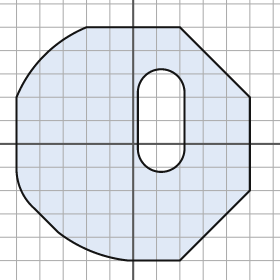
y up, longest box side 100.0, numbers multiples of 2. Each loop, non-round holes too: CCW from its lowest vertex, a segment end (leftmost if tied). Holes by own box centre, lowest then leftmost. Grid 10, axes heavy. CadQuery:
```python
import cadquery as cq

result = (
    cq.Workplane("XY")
    .moveTo(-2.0, -50.0)
    .lineTo(20.0, -50.0)
    .lineTo(50.0, -20.0)
    .lineTo(50.0, 20.0)
    .lineTo(20.0, 50.0)
    .lineTo(-20.0, 50.0)
    .threePointArc((-38.0, 38.0), (-50.0, 20.0))
    .lineTo(-50.0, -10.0)
    .threePointArc((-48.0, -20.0), (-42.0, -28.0))
    .lineTo(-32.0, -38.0)
    .threePointArc((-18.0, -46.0), (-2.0, -50.0))
    .close()
    .moveTo(2.0, -2.0)
    .threePointArc((12.0, -12.0), (22.0, -2.0))
    .lineTo(22.0, 22.0)
    .threePointArc((12.0, 32.0), (2.0, 22.0))
    .close()
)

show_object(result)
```